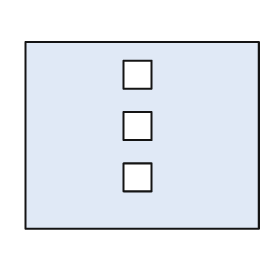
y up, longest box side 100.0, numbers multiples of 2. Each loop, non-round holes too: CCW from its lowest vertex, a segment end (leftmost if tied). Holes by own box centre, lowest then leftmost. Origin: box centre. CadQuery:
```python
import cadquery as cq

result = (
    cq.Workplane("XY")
    .moveTo(-50.0, -40.0)
    .lineTo(50.0, -40.0)
    .lineTo(50.0, 40.0)
    .lineTo(-50.0, 40.0)
    .close()
    .moveTo(-8.0, -24.0)
    .lineTo(4.0, -24.0)
    .lineTo(4.0, -12.0)
    .lineTo(-8.0, -12.0)
    .close()
    .moveTo(-8.0, -2.0)
    .lineTo(4.0, -2.0)
    .lineTo(4.0, 10.0)
    .lineTo(-8.0, 10.0)
    .close()
    .moveTo(-8.0, 20.0)
    .lineTo(4.0, 20.0)
    .lineTo(4.0, 32.0)
    .lineTo(-8.0, 32.0)
    .close()
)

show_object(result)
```